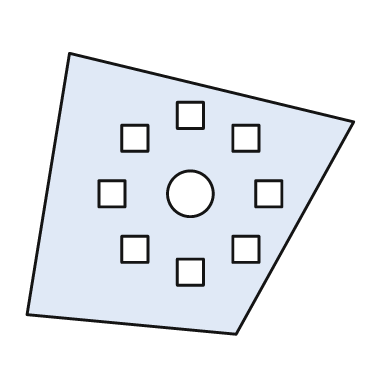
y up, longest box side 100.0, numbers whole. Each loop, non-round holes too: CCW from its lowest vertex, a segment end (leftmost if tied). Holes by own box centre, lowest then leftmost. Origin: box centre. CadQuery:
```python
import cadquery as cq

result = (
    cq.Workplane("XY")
    .moveTo(14.0, -43.0)
    .lineTo(50.0, 22.0)
    .lineTo(-37.0, 43.0)
    .lineTo(-50.0, -37.0)
    .close()
    .moveTo(-4.0, -28.0)
    .lineTo(4.0, -28.0)
    .lineTo(4.0, -20.0)
    .lineTo(-4.0, -20.0)
    .close()
    .moveTo(-21.0, -21.0)
    .lineTo(-13.0, -21.0)
    .lineTo(-13.0, -13.0)
    .lineTo(-21.0, -13.0)
    .close()
    .moveTo(13.0, -21.0)
    .lineTo(21.0, -21.0)
    .lineTo(21.0, -13.0)
    .lineTo(13.0, -13.0)
    .close()
    .moveTo(-28.0, -4.0)
    .lineTo(-20.0, -4.0)
    .lineTo(-20.0, 4.0)
    .lineTo(-28.0, 4.0)
    .close()
    .moveTo(0.0, 0.0)
    .circle(7.0)
    .moveTo(20.0, -4.0)
    .lineTo(28.0, -4.0)
    .lineTo(28.0, 4.0)
    .lineTo(20.0, 4.0)
    .close()
    .moveTo(-21.0, 13.0)
    .lineTo(-13.0, 13.0)
    .lineTo(-13.0, 21.0)
    .lineTo(-21.0, 21.0)
    .close()
    .moveTo(13.0, 13.0)
    .lineTo(21.0, 13.0)
    .lineTo(21.0, 21.0)
    .lineTo(13.0, 21.0)
    .close()
    .moveTo(-4.0, 20.0)
    .lineTo(4.0, 20.0)
    .lineTo(4.0, 28.0)
    .lineTo(-4.0, 28.0)
    .close()
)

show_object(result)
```